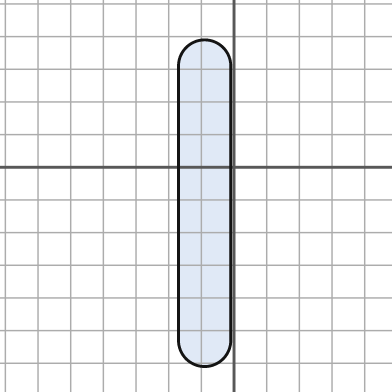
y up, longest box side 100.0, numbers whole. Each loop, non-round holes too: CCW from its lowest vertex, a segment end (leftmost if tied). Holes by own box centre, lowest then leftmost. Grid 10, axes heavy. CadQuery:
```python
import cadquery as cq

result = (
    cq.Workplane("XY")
    .moveTo(-17.0, -53.0)
    .threePointArc((-9.0, -61.0), (-1.0, -53.0))
    .lineTo(-1.0, 31.0)
    .threePointArc((-9.0, 39.0), (-17.0, 31.0))
    .close()
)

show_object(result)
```